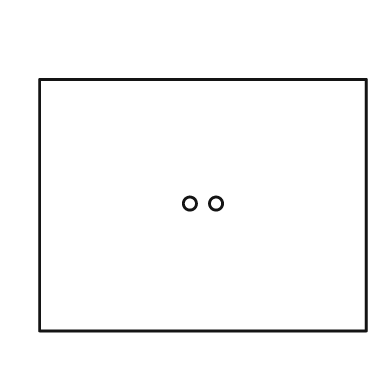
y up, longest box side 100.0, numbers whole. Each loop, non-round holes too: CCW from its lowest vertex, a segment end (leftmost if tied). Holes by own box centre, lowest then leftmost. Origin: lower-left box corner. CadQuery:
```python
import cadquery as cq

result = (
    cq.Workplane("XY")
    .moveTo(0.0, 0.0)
    .lineTo(100.0, 0.0)
    .lineTo(100.0, 77.0)
    .lineTo(0.0, 77.0)
    .close()
    .moveTo(46.0, 39.0)
    .circle(2.0)
    .moveTo(54.0, 39.0)
    .circle(2.0)
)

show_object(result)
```